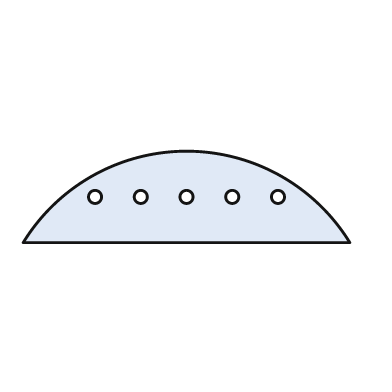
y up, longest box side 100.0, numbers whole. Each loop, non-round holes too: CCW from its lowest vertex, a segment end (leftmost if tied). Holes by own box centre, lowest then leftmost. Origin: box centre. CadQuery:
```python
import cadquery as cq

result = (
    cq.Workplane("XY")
    .moveTo(-50.0, -14.0)
    .lineTo(50.0, -14.0)
    .threePointArc((0.0, 14.0), (-50.0, -14.0))
    .close()
    .moveTo(-28.0, 0.0)
    .circle(2.0)
    .moveTo(-14.0, 0.0)
    .circle(2.0)
    .moveTo(0.0, 0.0)
    .circle(2.0)
    .moveTo(14.0, 0.0)
    .circle(2.0)
    .moveTo(28.0, 0.0)
    .circle(2.0)
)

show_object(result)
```